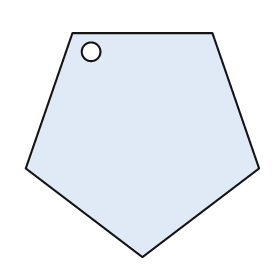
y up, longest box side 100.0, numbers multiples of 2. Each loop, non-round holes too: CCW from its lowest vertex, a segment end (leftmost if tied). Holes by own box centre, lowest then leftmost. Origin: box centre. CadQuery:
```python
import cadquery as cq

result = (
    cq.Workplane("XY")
    .moveTo(0.0, -48.0)
    .lineTo(50.0, -10.0)
    .lineTo(30.0, 48.0)
    .lineTo(-30.0, 48.0)
    .lineTo(-50.0, -10.0)
    .close()
    .moveTo(-22.0, 40.0)
    .circle(4.0)
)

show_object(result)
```